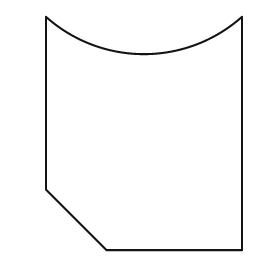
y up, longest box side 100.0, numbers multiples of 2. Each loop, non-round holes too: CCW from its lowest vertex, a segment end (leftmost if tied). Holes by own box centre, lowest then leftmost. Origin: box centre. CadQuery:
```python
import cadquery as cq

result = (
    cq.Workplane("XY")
    .moveTo(-16.0, -50.0)
    .lineTo(42.0, -50.0)
    .lineTo(42.0, 50.0)
    .threePointArc((0.0, 34.0), (-42.0, 50.0))
    .lineTo(-42.0, -24.0)
    .close()
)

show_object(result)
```